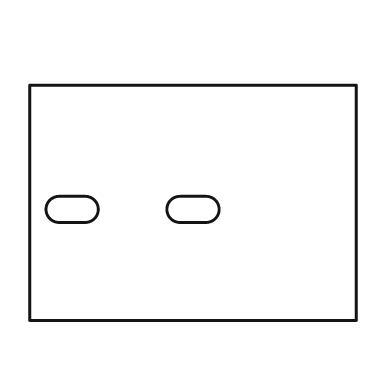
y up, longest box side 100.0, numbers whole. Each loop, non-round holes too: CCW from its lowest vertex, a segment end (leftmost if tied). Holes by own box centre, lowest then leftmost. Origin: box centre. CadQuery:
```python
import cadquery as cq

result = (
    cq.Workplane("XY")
    .moveTo(-50.0, -36.0)
    .lineTo(50.0, -36.0)
    .lineTo(50.0, 36.0)
    .lineTo(-50.0, 36.0)
    .close()
    .moveTo(-41.0, -6.0)
    .lineTo(-33.0, -6.0)
    .threePointArc((-29.0, -2.0), (-33.0, 2.0))
    .lineTo(-41.0, 2.0)
    .threePointArc((-45.0, -2.0), (-41.0, -6.0))
    .close()
    .moveTo(-4.0, -6.0)
    .lineTo(4.0, -6.0)
    .threePointArc((8.0, -2.0), (4.0, 2.0))
    .lineTo(-4.0, 2.0)
    .threePointArc((-8.0, -2.0), (-4.0, -6.0))
    .close()
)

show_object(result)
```